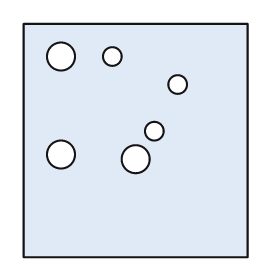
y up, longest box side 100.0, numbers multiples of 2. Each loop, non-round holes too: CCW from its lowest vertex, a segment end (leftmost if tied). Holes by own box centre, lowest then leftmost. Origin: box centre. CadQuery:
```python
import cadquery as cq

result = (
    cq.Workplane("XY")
    .moveTo(-48.0, -50.0)
    .lineTo(48.0, -50.0)
    .lineTo(48.0, 50.0)
    .lineTo(-48.0, 50.0)
    .close()
    .moveTo(0.0, -8.0)
    .circle(6.0)
    .moveTo(-32.0, -6.0)
    .circle(6.0)
    .moveTo(8.0, 4.0)
    .circle(4.0)
    .moveTo(18.0, 24.0)
    .circle(4.0)
    .moveTo(-32.0, 36.0)
    .circle(6.0)
    .moveTo(-10.0, 36.0)
    .circle(4.0)
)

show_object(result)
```